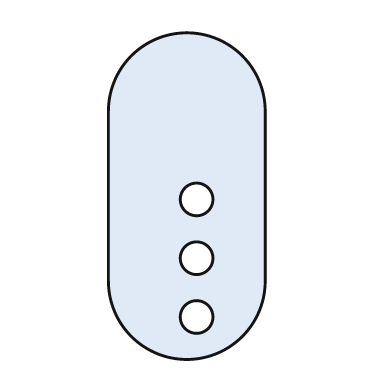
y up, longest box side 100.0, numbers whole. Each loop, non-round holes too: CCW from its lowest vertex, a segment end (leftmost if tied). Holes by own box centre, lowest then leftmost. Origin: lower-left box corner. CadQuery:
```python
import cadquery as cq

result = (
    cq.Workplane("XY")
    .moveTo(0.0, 24.0)
    .threePointArc((24.0, 0.0), (48.0, 24.0))
    .lineTo(48.0, 76.0)
    .threePointArc((24.0, 100.0), (0.0, 76.0))
    .close()
    .moveTo(27.0, 13.0)
    .circle(5.0)
    .moveTo(27.0, 31.0)
    .circle(5.0)
    .moveTo(27.0, 49.0)
    .circle(5.0)
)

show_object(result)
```